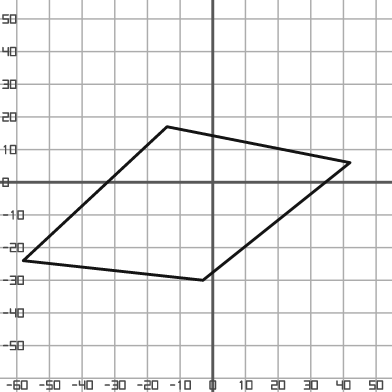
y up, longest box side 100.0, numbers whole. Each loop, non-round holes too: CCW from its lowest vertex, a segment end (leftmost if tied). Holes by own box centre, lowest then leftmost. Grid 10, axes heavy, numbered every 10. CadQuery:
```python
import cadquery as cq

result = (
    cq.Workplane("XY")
    .moveTo(-3.0, -30.0)
    .lineTo(42.0, 6.0)
    .lineTo(-14.0, 17.0)
    .lineTo(-58.0, -24.0)
    .close()
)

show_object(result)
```